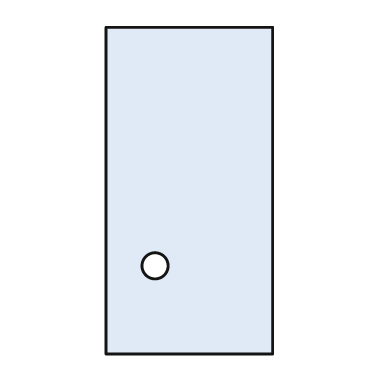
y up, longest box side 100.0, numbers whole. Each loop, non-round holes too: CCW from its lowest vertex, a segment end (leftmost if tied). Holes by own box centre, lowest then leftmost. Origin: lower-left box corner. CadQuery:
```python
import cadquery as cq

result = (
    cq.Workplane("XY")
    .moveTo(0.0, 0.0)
    .lineTo(51.0, 0.0)
    .lineTo(51.0, 100.0)
    .lineTo(0.0, 100.0)
    .close()
    .moveTo(15.0, 27.0)
    .circle(4.0)
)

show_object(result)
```